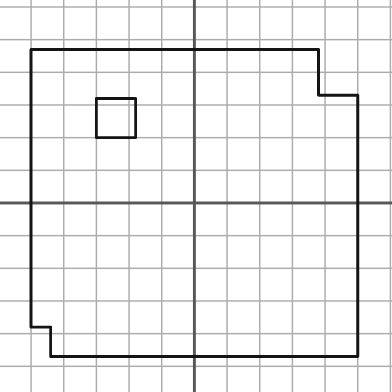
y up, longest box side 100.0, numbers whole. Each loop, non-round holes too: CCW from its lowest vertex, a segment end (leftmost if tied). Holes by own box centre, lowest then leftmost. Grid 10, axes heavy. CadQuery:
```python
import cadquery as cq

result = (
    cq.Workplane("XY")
    .moveTo(-44.0, -47.0)
    .lineTo(50.0, -47.0)
    .lineTo(50.0, 33.0)
    .lineTo(38.0, 33.0)
    .lineTo(38.0, 47.0)
    .lineTo(-50.0, 47.0)
    .lineTo(-50.0, -38.0)
    .lineTo(-44.0, -38.0)
    .close()
    .moveTo(-30.0, 20.0)
    .lineTo(-18.0, 20.0)
    .lineTo(-18.0, 32.0)
    .lineTo(-30.0, 32.0)
    .close()
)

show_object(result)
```